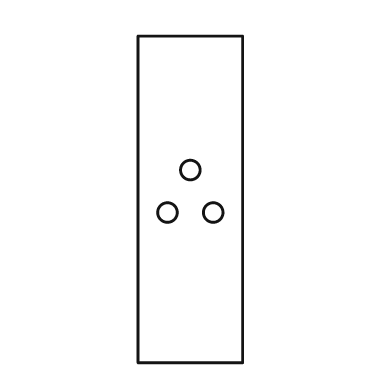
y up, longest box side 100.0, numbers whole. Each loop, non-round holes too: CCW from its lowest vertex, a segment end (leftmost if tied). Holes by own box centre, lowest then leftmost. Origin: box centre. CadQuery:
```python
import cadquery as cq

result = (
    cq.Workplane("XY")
    .moveTo(-16.0, -50.0)
    .lineTo(16.0, -50.0)
    .lineTo(16.0, 50.0)
    .lineTo(-16.0, 50.0)
    .close()
    .moveTo(-7.0, -4.0)
    .circle(3.0)
    .moveTo(7.0, -4.0)
    .circle(3.0)
    .moveTo(0.0, 9.0)
    .circle(3.0)
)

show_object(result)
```